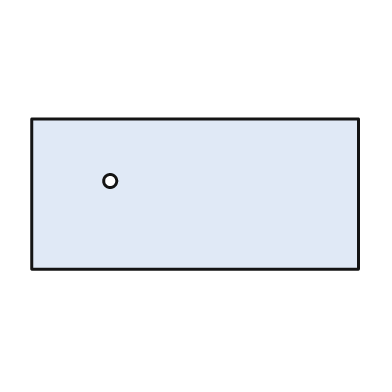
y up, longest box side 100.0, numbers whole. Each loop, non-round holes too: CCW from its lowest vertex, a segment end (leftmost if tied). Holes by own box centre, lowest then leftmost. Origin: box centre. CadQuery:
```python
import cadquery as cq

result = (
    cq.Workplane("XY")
    .moveTo(-50.0, -23.0)
    .lineTo(50.0, -23.0)
    .lineTo(50.0, 23.0)
    .lineTo(-50.0, 23.0)
    .close()
    .moveTo(-26.0, 4.0)
    .circle(2.0)
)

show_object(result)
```